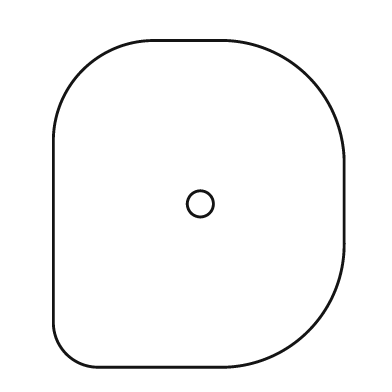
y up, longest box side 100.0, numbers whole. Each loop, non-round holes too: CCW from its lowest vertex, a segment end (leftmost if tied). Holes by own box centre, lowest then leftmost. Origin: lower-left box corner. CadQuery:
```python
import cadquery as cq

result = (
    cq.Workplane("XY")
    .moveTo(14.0, 0.0)
    .lineTo(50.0, 0.0)
    .threePointArc((78.0, 11.0), (89.0, 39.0))
    .lineTo(89.0, 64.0)
    .threePointArc((78.0, 89.0), (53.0, 100.0))
    .lineTo(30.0, 100.0)
    .threePointArc((9.0, 91.0), (0.0, 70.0))
    .lineTo(0.0, 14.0)
    .threePointArc((4.0, 4.0), (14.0, 0.0))
    .close()
    .moveTo(45.0, 50.0)
    .circle(4.0)
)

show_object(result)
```